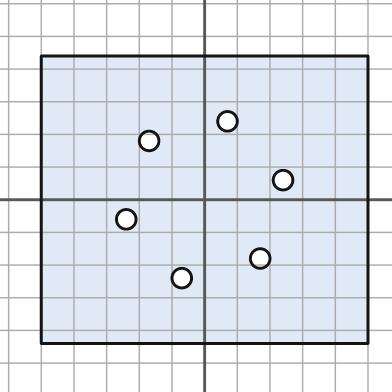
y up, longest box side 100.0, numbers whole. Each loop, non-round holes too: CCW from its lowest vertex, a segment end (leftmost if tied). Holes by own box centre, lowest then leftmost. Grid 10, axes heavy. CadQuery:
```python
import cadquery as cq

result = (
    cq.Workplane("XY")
    .moveTo(-50.0, -44.0)
    .lineTo(50.0, -44.0)
    .lineTo(50.0, 44.0)
    .lineTo(-50.0, 44.0)
    .close()
    .moveTo(-7.0, -24.0)
    .circle(3.0)
    .moveTo(17.0, -18.0)
    .circle(3.0)
    .moveTo(-24.0, -6.0)
    .circle(3.0)
    .moveTo(24.0, 6.0)
    .circle(3.0)
    .moveTo(-17.0, 18.0)
    .circle(3.0)
    .moveTo(7.0, 24.0)
    .circle(3.0)
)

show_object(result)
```